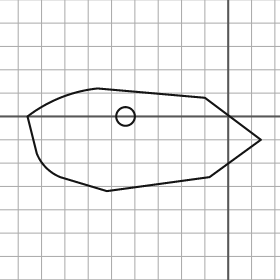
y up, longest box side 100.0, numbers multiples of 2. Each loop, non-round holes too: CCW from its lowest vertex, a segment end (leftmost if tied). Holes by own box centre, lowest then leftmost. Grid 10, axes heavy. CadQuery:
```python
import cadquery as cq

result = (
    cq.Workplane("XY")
    .moveTo(-52.0, -32.0)
    .lineTo(-8.0, -26.0)
    .lineTo(14.0, -10.0)
    .lineTo(-10.0, 8.0)
    .lineTo(-56.0, 12.0)
    .threePointArc((-72.0, 8.0), (-86.0, 0.0))
    .lineTo(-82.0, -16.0)
    .threePointArc((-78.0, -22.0), (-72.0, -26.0))
    .close()
    .moveTo(-44.0, 0.0)
    .circle(4.0)
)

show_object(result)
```